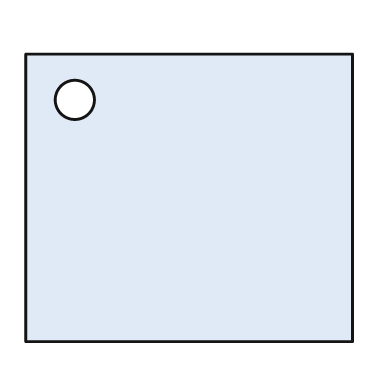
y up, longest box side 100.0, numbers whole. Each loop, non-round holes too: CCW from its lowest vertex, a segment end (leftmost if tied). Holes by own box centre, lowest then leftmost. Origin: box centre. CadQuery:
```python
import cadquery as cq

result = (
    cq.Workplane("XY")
    .moveTo(-50.0, -44.0)
    .lineTo(50.0, -44.0)
    .lineTo(50.0, 44.0)
    .lineTo(-50.0, 44.0)
    .close()
    .moveTo(-35.0, 30.0)
    .circle(6.0)
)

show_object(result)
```